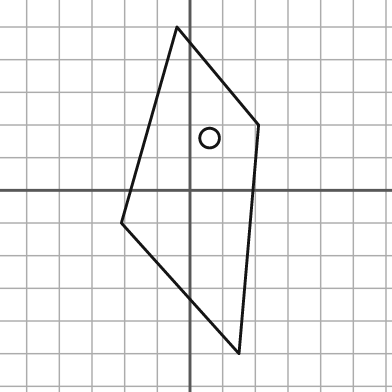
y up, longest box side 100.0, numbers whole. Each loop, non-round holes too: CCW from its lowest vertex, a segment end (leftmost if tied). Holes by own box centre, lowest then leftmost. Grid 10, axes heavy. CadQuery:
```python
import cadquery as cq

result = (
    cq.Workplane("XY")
    .moveTo(15.0, -50.0)
    .lineTo(21.0, 20.0)
    .lineTo(-4.0, 50.0)
    .lineTo(-21.0, -10.0)
    .close()
    .moveTo(6.0, 16.0)
    .circle(3.0)
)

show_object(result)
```